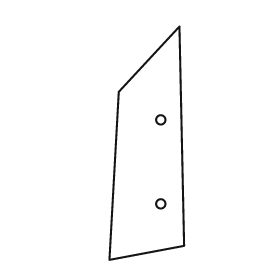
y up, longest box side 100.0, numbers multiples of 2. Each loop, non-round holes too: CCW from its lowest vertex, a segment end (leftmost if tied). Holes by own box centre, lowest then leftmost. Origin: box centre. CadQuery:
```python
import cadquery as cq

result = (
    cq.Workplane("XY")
    .moveTo(-16.0, -50.0)
    .lineTo(16.0, -44.0)
    .lineTo(14.0, 50.0)
    .lineTo(-12.0, 22.0)
    .close()
    .moveTo(6.0, -26.0)
    .circle(2.0)
    .moveTo(6.0, 10.0)
    .circle(2.0)
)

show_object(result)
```